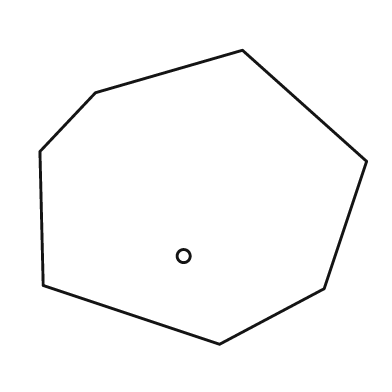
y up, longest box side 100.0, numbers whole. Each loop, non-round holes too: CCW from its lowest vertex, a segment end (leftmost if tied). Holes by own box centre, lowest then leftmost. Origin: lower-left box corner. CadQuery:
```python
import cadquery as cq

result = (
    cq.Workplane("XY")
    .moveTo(55.0, 0.0)
    .lineTo(87.0, 17.0)
    .lineTo(100.0, 56.0)
    .lineTo(62.0, 90.0)
    .lineTo(17.0, 77.0)
    .lineTo(0.0, 59.0)
    .lineTo(1.0, 18.0)
    .close()
    .moveTo(44.0, 27.0)
    .circle(2.0)
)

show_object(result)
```